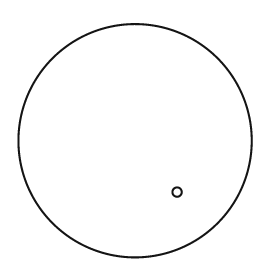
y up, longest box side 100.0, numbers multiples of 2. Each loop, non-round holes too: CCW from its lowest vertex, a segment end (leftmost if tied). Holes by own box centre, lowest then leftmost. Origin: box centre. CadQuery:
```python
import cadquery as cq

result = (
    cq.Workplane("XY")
    .moveTo(0.0, 0.0)
    .circle(50.0)
    .moveTo(18.0, -22.0)
    .circle(2.0)
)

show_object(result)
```